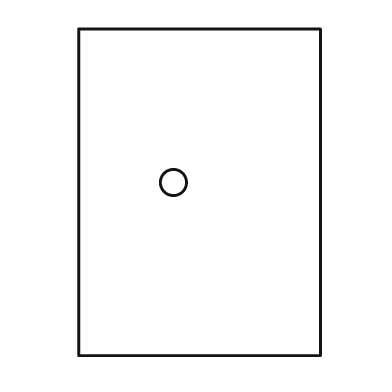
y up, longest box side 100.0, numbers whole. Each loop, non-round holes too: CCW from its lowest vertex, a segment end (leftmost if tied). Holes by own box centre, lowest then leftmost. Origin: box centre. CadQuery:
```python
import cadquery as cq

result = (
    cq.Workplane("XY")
    .moveTo(-37.0, -50.0)
    .lineTo(37.0, -50.0)
    .lineTo(37.0, 50.0)
    .lineTo(-37.0, 50.0)
    .close()
    .moveTo(-8.0, 3.0)
    .circle(4.0)
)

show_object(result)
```